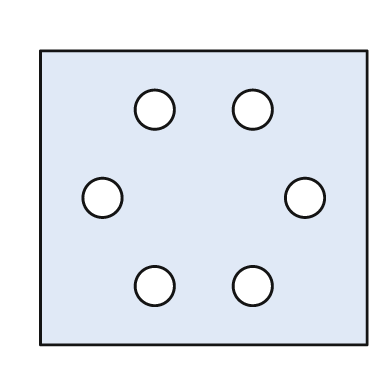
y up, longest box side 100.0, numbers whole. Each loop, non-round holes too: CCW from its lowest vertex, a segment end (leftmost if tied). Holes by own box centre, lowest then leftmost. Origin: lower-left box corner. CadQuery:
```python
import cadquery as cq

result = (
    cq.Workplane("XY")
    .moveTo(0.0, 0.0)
    .lineTo(100.0, 0.0)
    .lineTo(100.0, 90.0)
    .lineTo(0.0, 90.0)
    .close()
    .moveTo(35.0, 18.0)
    .circle(6.0)
    .moveTo(65.0, 18.0)
    .circle(6.0)
    .moveTo(19.0, 45.0)
    .circle(6.0)
    .moveTo(81.0, 45.0)
    .circle(6.0)
    .moveTo(35.0, 72.0)
    .circle(6.0)
    .moveTo(65.0, 72.0)
    .circle(6.0)
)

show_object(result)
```